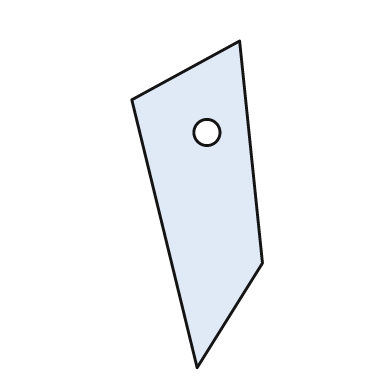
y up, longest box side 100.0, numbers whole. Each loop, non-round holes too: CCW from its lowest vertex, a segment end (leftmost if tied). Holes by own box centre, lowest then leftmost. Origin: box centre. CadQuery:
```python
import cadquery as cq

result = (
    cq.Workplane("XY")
    .moveTo(0.0, -50.0)
    .lineTo(20.0, -18.0)
    .lineTo(13.0, 50.0)
    .lineTo(-20.0, 32.0)
    .close()
    .moveTo(3.0, 22.0)
    .circle(4.0)
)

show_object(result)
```